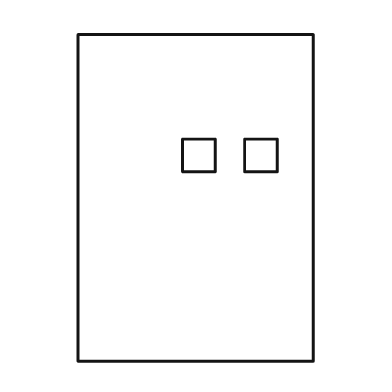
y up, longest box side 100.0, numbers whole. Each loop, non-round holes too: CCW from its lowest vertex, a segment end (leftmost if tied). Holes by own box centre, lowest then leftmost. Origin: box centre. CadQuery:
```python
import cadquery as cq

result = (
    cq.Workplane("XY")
    .moveTo(-36.0, -50.0)
    .lineTo(36.0, -50.0)
    .lineTo(36.0, 50.0)
    .lineTo(-36.0, 50.0)
    .close()
    .moveTo(-4.0, 8.0)
    .lineTo(6.0, 8.0)
    .lineTo(6.0, 18.0)
    .lineTo(-4.0, 18.0)
    .close()
    .moveTo(15.0, 8.0)
    .lineTo(25.0, 8.0)
    .lineTo(25.0, 18.0)
    .lineTo(15.0, 18.0)
    .close()
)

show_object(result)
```